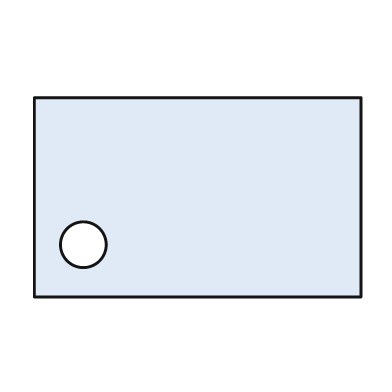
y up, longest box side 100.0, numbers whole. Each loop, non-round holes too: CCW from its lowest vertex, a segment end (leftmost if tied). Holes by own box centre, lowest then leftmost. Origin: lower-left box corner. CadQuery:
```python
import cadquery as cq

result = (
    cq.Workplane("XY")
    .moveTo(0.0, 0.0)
    .lineTo(100.0, 0.0)
    .lineTo(100.0, 61.0)
    .lineTo(0.0, 61.0)
    .close()
    .moveTo(15.0, 16.0)
    .circle(7.0)
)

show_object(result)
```